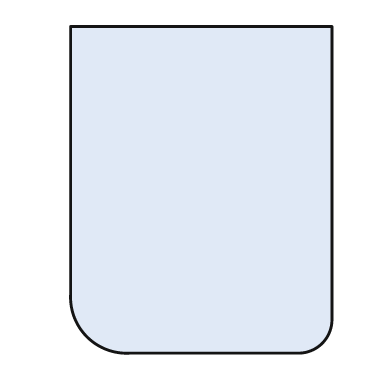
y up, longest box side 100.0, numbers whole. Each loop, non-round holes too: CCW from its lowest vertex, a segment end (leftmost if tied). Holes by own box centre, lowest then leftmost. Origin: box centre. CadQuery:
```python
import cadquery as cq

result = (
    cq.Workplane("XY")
    .moveTo(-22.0, -50.0)
    .lineTo(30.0, -50.0)
    .threePointArc((37.0, -47.0), (40.0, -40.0))
    .lineTo(40.0, 50.0)
    .lineTo(-40.0, 50.0)
    .lineTo(-40.0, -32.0)
    .threePointArc((-35.0, -45.0), (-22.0, -50.0))
    .close()
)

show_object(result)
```